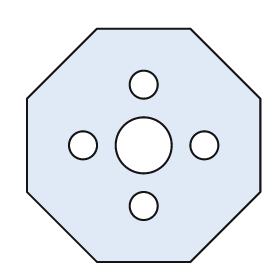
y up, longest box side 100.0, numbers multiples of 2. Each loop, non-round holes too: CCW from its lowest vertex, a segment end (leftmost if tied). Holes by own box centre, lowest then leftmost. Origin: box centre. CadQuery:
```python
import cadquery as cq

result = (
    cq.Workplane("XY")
    .moveTo(-20.0, -50.0)
    .lineTo(20.0, -50.0)
    .lineTo(50.0, -20.0)
    .lineTo(50.0, 20.0)
    .lineTo(20.0, 50.0)
    .lineTo(-20.0, 50.0)
    .lineTo(-50.0, 20.0)
    .lineTo(-50.0, -20.0)
    .close()
    .moveTo(0.0, -26.0)
    .circle(6.0)
    .moveTo(-26.0, 0.0)
    .circle(6.0)
    .moveTo(0.0, 0.0)
    .circle(12.0)
    .moveTo(26.0, 0.0)
    .circle(6.0)
    .moveTo(0.0, 26.0)
    .circle(6.0)
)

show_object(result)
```